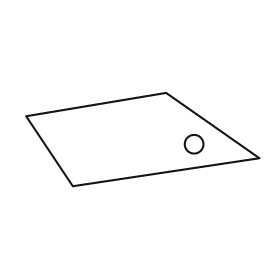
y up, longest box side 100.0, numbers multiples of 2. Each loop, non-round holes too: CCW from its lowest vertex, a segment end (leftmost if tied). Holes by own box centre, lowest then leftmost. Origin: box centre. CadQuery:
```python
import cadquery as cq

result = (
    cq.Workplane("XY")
    .moveTo(-30.0, -20.0)
    .lineTo(50.0, -8.0)
    .lineTo(10.0, 20.0)
    .lineTo(-50.0, 10.0)
    .close()
    .moveTo(22.0, -2.0)
    .circle(4.0)
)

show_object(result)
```